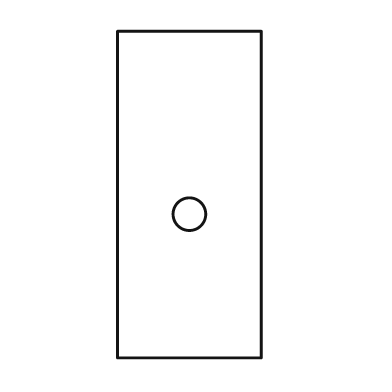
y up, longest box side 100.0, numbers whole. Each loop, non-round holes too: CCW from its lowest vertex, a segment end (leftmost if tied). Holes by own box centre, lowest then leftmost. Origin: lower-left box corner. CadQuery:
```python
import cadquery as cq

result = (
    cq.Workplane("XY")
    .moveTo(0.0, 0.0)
    .lineTo(44.0, 0.0)
    .lineTo(44.0, 100.0)
    .lineTo(0.0, 100.0)
    .close()
    .moveTo(22.0, 44.0)
    .circle(5.0)
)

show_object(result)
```